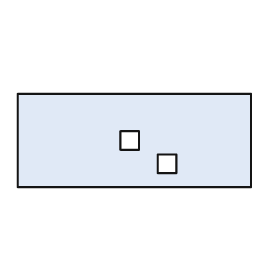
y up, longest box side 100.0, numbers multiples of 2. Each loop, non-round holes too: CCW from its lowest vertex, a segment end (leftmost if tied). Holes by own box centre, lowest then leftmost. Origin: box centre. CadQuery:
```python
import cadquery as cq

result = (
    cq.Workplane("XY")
    .moveTo(-50.0, -20.0)
    .lineTo(50.0, -20.0)
    .lineTo(50.0, 20.0)
    .lineTo(-50.0, 20.0)
    .close()
    .moveTo(10.0, -14.0)
    .lineTo(18.0, -14.0)
    .lineTo(18.0, -6.0)
    .lineTo(10.0, -6.0)
    .close()
    .moveTo(-6.0, -4.0)
    .lineTo(2.0, -4.0)
    .lineTo(2.0, 4.0)
    .lineTo(-6.0, 4.0)
    .close()
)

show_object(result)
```